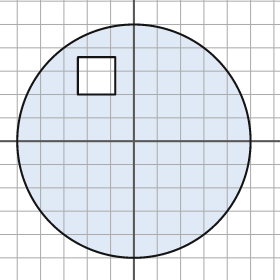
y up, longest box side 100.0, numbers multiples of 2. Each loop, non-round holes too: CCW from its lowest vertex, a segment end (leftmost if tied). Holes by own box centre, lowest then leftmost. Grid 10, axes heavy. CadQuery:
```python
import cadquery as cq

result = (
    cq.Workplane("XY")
    .moveTo(0.0, 0.0)
    .circle(50.0)
    .moveTo(-24.0, 20.0)
    .lineTo(-8.0, 20.0)
    .lineTo(-8.0, 36.0)
    .lineTo(-24.0, 36.0)
    .close()
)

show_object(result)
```